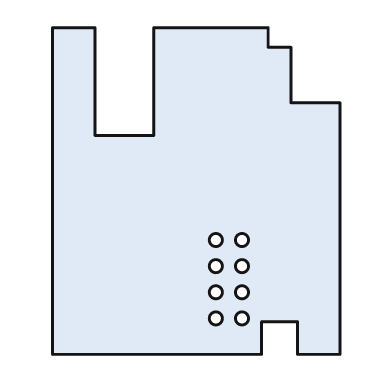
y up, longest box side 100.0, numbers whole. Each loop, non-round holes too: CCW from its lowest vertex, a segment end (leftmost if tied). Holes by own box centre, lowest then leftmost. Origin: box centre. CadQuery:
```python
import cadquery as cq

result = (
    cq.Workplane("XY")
    .moveTo(-44.0, -50.0)
    .lineTo(20.0, -50.0)
    .lineTo(20.0, -40.0)
    .lineTo(31.0, -40.0)
    .lineTo(31.0, -50.0)
    .lineTo(44.0, -50.0)
    .lineTo(44.0, 27.0)
    .lineTo(29.0, 27.0)
    .lineTo(29.0, 44.0)
    .lineTo(22.0, 44.0)
    .lineTo(22.0, 50.0)
    .lineTo(-13.0, 50.0)
    .lineTo(-13.0, 17.0)
    .lineTo(-31.0, 17.0)
    .lineTo(-31.0, 50.0)
    .lineTo(-44.0, 50.0)
    .close()
    .moveTo(6.0, -39.0)
    .circle(2.0)
    .moveTo(14.0, -39.0)
    .circle(2.0)
    .moveTo(6.0, -31.0)
    .circle(2.0)
    .moveTo(14.0, -31.0)
    .circle(2.0)
    .moveTo(6.0, -23.0)
    .circle(2.0)
    .moveTo(14.0, -23.0)
    .circle(2.0)
    .moveTo(6.0, -15.0)
    .circle(2.0)
    .moveTo(14.0, -15.0)
    .circle(2.0)
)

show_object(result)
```